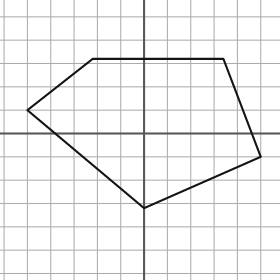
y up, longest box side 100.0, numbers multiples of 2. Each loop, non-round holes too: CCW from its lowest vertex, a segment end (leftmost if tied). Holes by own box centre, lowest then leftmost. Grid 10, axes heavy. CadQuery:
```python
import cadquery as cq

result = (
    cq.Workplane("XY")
    .moveTo(0.0, -32.0)
    .lineTo(50.0, -10.0)
    .lineTo(34.0, 32.0)
    .lineTo(-22.0, 32.0)
    .lineTo(-50.0, 10.0)
    .close()
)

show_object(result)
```